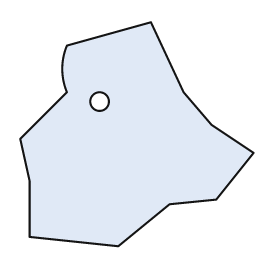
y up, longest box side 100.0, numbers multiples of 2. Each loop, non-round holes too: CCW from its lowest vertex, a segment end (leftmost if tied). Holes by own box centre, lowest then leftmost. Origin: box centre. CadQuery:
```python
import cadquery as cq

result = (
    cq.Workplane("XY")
    .moveTo(-8.0, -48.0)
    .lineTo(14.0, -30.0)
    .lineTo(34.0, -28.0)
    .lineTo(50.0, -8.0)
    .lineTo(32.0, 4.0)
    .lineTo(20.0, 18.0)
    .lineTo(6.0, 48.0)
    .lineTo(-30.0, 38.0)
    .threePointArc((-32.0, 28.0), (-30.0, 18.0))
    .lineTo(-50.0, -2.0)
    .lineTo(-46.0, -20.0)
    .lineTo(-46.0, -44.0)
    .close()
    .moveTo(-16.0, 14.0)
    .circle(4.0)
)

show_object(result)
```